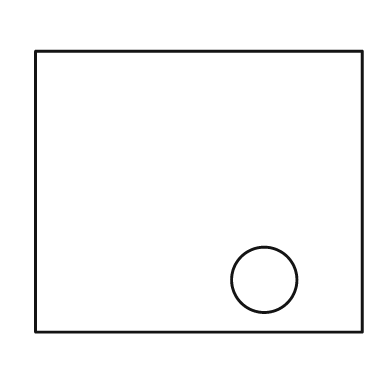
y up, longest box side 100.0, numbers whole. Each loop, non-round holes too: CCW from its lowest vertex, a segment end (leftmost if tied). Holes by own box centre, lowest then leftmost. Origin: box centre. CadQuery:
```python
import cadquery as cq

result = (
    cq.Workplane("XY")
    .moveTo(-50.0, -43.0)
    .lineTo(50.0, -43.0)
    .lineTo(50.0, 43.0)
    .lineTo(-50.0, 43.0)
    .close()
    .moveTo(20.0, -27.0)
    .circle(10.0)
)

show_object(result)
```